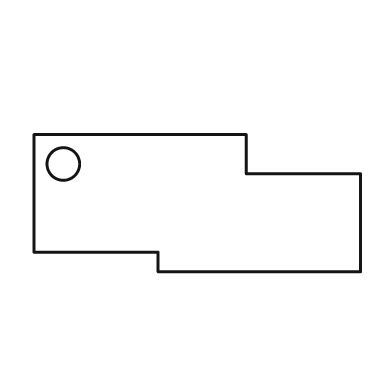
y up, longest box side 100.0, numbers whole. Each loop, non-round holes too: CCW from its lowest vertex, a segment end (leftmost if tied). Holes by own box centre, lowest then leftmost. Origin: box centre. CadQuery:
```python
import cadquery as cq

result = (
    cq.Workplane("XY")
    .moveTo(-12.0, -21.0)
    .lineTo(50.0, -21.0)
    .lineTo(50.0, 9.0)
    .lineTo(15.0, 9.0)
    .lineTo(15.0, 21.0)
    .lineTo(-50.0, 21.0)
    .lineTo(-50.0, -15.0)
    .lineTo(-12.0, -15.0)
    .close()
    .moveTo(-41.0, 12.0)
    .circle(5.0)
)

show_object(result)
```